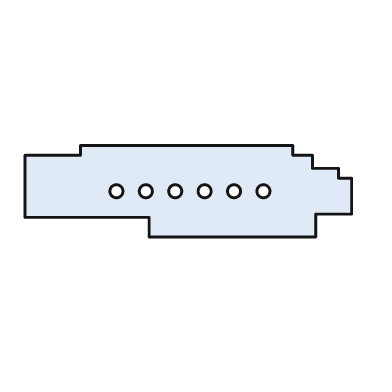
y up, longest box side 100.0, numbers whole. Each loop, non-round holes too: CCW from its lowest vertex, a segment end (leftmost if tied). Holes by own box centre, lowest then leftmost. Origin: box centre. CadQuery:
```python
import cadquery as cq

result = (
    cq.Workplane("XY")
    .moveTo(-12.0, -14.0)
    .lineTo(39.0, -14.0)
    .lineTo(39.0, -7.0)
    .lineTo(50.0, -7.0)
    .lineTo(50.0, 4.0)
    .lineTo(46.0, 4.0)
    .lineTo(46.0, 7.0)
    .lineTo(38.0, 7.0)
    .lineTo(38.0, 11.0)
    .lineTo(32.0, 11.0)
    .lineTo(32.0, 14.0)
    .lineTo(-33.0, 14.0)
    .lineTo(-33.0, 11.0)
    .lineTo(-50.0, 11.0)
    .lineTo(-50.0, -8.0)
    .lineTo(-12.0, -8.0)
    .close()
    .moveTo(-22.0, 0.0)
    .circle(2.0)
    .moveTo(-13.0, 0.0)
    .circle(2.0)
    .moveTo(-4.0, 0.0)
    .circle(2.0)
    .moveTo(5.0, 0.0)
    .circle(2.0)
    .moveTo(14.0, 0.0)
    .circle(2.0)
    .moveTo(23.0, 0.0)
    .circle(2.0)
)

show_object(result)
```